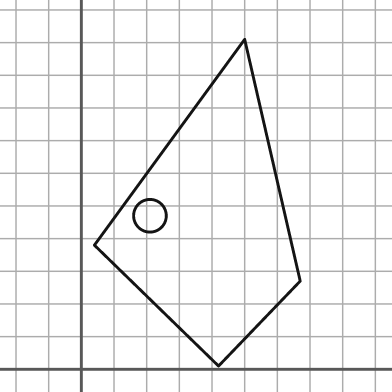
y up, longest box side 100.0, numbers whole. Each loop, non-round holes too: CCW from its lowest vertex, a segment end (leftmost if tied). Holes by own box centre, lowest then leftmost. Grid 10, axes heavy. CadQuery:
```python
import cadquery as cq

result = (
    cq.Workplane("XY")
    .moveTo(42.0, 1.0)
    .lineTo(67.0, 27.0)
    .lineTo(50.0, 101.0)
    .lineTo(4.0, 38.0)
    .close()
    .moveTo(21.0, 47.0)
    .circle(5.0)
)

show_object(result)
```